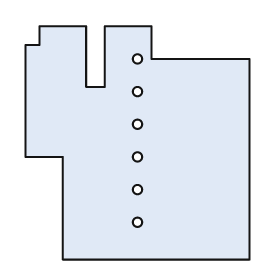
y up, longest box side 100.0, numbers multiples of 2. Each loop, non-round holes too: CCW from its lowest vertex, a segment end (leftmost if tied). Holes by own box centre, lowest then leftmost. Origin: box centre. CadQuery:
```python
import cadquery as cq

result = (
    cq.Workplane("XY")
    .moveTo(-32.0, -50.0)
    .lineTo(48.0, -50.0)
    .lineTo(48.0, 36.0)
    .lineTo(6.0, 36.0)
    .lineTo(6.0, 50.0)
    .lineTo(-14.0, 50.0)
    .lineTo(-14.0, 24.0)
    .lineTo(-22.0, 24.0)
    .lineTo(-22.0, 50.0)
    .lineTo(-42.0, 50.0)
    .lineTo(-42.0, 42.0)
    .lineTo(-48.0, 42.0)
    .lineTo(-48.0, -6.0)
    .lineTo(-32.0, -6.0)
    .close()
    .moveTo(0.0, -34.0)
    .circle(2.0)
    .moveTo(0.0, -20.0)
    .circle(2.0)
    .moveTo(0.0, -6.0)
    .circle(2.0)
    .moveTo(0.0, 8.0)
    .circle(2.0)
    .moveTo(0.0, 22.0)
    .circle(2.0)
    .moveTo(0.0, 36.0)
    .circle(2.0)
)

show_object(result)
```